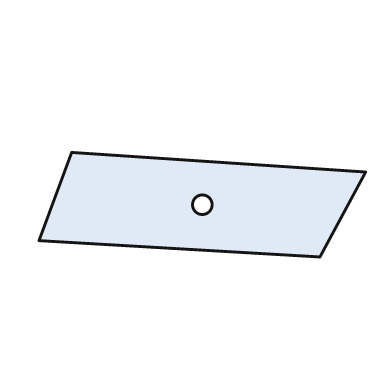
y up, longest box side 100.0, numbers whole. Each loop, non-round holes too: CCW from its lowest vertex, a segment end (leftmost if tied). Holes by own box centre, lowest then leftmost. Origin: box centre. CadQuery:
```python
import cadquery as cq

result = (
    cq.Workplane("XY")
    .moveTo(36.0, -16.0)
    .lineTo(50.0, 10.0)
    .lineTo(-40.0, 16.0)
    .lineTo(-50.0, -11.0)
    .close()
    .moveTo(0.0, 0.0)
    .circle(3.0)
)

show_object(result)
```